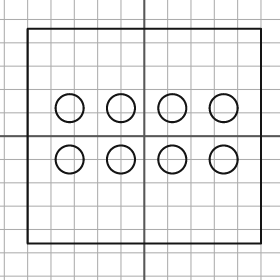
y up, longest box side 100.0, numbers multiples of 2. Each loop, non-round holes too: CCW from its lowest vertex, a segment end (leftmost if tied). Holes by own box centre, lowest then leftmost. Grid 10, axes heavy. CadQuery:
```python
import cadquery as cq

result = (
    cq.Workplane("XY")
    .moveTo(-50.0, -46.0)
    .lineTo(50.0, -46.0)
    .lineTo(50.0, 46.0)
    .lineTo(-50.0, 46.0)
    .close()
    .moveTo(-32.0, -10.0)
    .circle(6.0)
    .moveTo(-10.0, -10.0)
    .circle(6.0)
    .moveTo(12.0, -10.0)
    .circle(6.0)
    .moveTo(34.0, -10.0)
    .circle(6.0)
    .moveTo(-32.0, 12.0)
    .circle(6.0)
    .moveTo(-10.0, 12.0)
    .circle(6.0)
    .moveTo(12.0, 12.0)
    .circle(6.0)
    .moveTo(34.0, 12.0)
    .circle(6.0)
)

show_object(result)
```